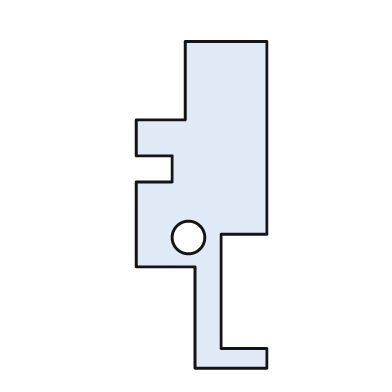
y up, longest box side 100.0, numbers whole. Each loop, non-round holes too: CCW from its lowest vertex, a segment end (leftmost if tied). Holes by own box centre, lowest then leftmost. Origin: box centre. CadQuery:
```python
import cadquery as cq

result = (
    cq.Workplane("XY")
    .moveTo(-2.0, -50.0)
    .lineTo(20.0, -50.0)
    .lineTo(20.0, -44.0)
    .lineTo(6.0, -44.0)
    .lineTo(6.0, -9.0)
    .lineTo(20.0, -9.0)
    .lineTo(20.0, 50.0)
    .lineTo(-5.0, 50.0)
    .lineTo(-5.0, 26.0)
    .lineTo(-20.0, 26.0)
    .lineTo(-20.0, 15.0)
    .lineTo(-9.0, 15.0)
    .lineTo(-9.0, 7.0)
    .lineTo(-20.0, 7.0)
    .lineTo(-20.0, -19.0)
    .lineTo(-2.0, -19.0)
    .close()
    .moveTo(-4.0, -10.0)
    .circle(5.0)
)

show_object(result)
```